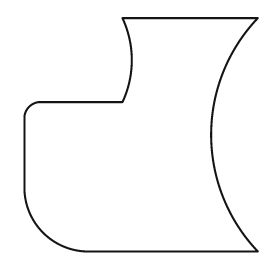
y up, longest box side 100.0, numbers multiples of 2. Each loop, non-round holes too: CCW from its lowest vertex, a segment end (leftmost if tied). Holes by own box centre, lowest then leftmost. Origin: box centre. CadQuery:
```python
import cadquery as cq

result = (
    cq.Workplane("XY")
    .moveTo(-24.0, -50.0)
    .lineTo(50.0, -50.0)
    .threePointArc((30.0, 0.0), (50.0, 50.0))
    .lineTo(-8.0, 50.0)
    .threePointArc((-4.0, 32.0), (-8.0, 14.0))
    .lineTo(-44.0, 14.0)
    .threePointArc((-48.0, 12.0), (-50.0, 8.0))
    .lineTo(-50.0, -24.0)
    .threePointArc((-42.0, -42.0), (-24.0, -50.0))
    .close()
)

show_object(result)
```